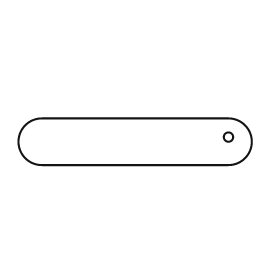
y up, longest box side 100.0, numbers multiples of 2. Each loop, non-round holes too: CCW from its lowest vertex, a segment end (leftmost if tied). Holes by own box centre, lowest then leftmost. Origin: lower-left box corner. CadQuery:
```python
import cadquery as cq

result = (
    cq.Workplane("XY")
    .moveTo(10.0, 0.0)
    .lineTo(90.0, 0.0)
    .threePointArc((100.0, 10.0), (90.0, 20.0))
    .lineTo(10.0, 20.0)
    .threePointArc((0.0, 10.0), (10.0, 0.0))
    .close()
    .moveTo(90.0, 12.0)
    .circle(2.0)
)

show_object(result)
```